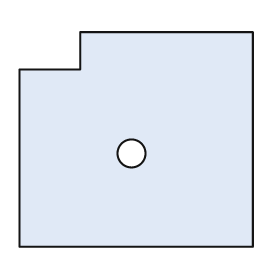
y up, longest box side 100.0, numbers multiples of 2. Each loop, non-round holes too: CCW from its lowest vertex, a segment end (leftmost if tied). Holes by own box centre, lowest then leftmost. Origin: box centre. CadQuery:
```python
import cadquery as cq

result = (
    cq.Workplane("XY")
    .moveTo(-50.0, -46.0)
    .lineTo(50.0, -46.0)
    .lineTo(50.0, 46.0)
    .lineTo(-24.0, 46.0)
    .lineTo(-24.0, 30.0)
    .lineTo(-50.0, 30.0)
    .close()
    .moveTo(-2.0, -6.0)
    .circle(6.0)
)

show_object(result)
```